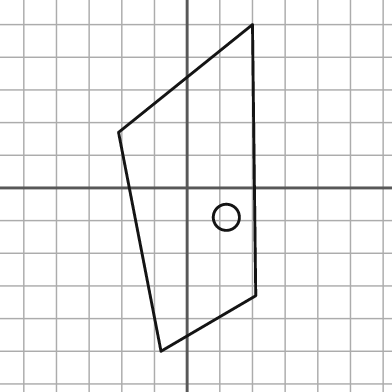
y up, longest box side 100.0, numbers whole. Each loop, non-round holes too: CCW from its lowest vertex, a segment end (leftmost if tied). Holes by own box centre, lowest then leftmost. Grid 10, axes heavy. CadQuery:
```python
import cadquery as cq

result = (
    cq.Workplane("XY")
    .moveTo(-8.0, -50.0)
    .lineTo(21.0, -33.0)
    .lineTo(20.0, 50.0)
    .lineTo(-21.0, 17.0)
    .close()
    .moveTo(12.0, -9.0)
    .circle(4.0)
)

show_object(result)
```